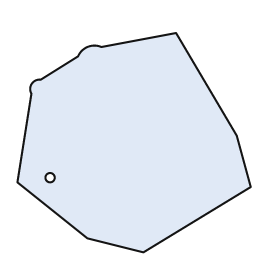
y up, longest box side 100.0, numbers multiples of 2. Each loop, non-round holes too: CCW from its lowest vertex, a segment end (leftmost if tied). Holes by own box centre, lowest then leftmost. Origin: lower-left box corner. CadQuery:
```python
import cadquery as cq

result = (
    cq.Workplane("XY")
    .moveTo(54.0, 0.0)
    .lineTo(100.0, 28.0)
    .lineTo(94.0, 50.0)
    .lineTo(68.0, 94.0)
    .lineTo(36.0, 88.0)
    .threePointArc((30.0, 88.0), (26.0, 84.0))
    .lineTo(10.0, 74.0)
    .threePointArc((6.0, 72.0), (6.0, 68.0))
    .lineTo(0.0, 30.0)
    .lineTo(30.0, 6.0)
    .close()
    .moveTo(14.0, 32.0)
    .circle(2.0)
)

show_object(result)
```